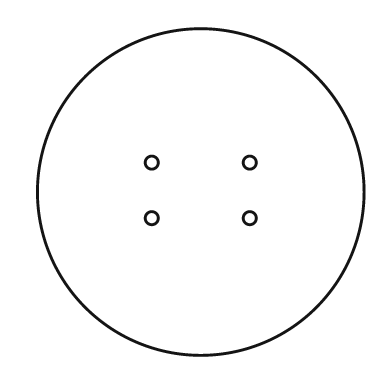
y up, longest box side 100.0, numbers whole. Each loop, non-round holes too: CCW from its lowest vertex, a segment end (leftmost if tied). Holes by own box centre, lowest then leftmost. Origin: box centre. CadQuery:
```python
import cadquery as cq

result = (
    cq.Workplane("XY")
    .moveTo(0.0, 0.0)
    .circle(50.0)
    .moveTo(-15.0, -8.0)
    .circle(2.0)
    .moveTo(15.0, -8.0)
    .circle(2.0)
    .moveTo(-15.0, 9.0)
    .circle(2.0)
    .moveTo(15.0, 9.0)
    .circle(2.0)
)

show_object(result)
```